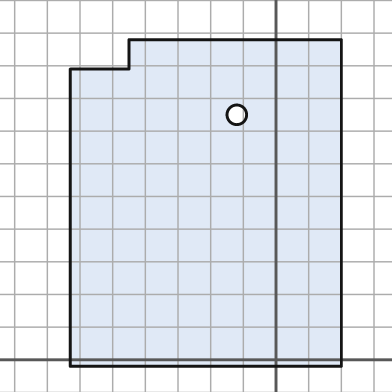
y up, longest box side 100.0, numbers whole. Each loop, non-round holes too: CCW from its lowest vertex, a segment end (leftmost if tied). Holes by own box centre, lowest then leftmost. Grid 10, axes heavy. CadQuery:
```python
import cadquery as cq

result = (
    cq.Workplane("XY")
    .moveTo(-63.0, -2.0)
    .lineTo(20.0, -2.0)
    .lineTo(20.0, 98.0)
    .lineTo(-45.0, 98.0)
    .lineTo(-45.0, 89.0)
    .lineTo(-63.0, 89.0)
    .close()
    .moveTo(-12.0, 75.0)
    .circle(3.0)
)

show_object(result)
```